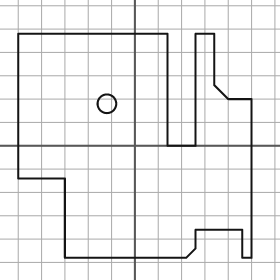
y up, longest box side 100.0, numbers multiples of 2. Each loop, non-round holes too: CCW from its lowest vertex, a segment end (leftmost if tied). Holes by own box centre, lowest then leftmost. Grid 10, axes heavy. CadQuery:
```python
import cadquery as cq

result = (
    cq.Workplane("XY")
    .moveTo(-30.0, -48.0)
    .lineTo(22.0, -48.0)
    .lineTo(26.0, -44.0)
    .lineTo(26.0, -36.0)
    .lineTo(46.0, -36.0)
    .lineTo(46.0, -48.0)
    .lineTo(50.0, -48.0)
    .lineTo(50.0, 20.0)
    .lineTo(40.0, 20.0)
    .lineTo(34.0, 26.0)
    .lineTo(34.0, 48.0)
    .lineTo(26.0, 48.0)
    .lineTo(26.0, 0.0)
    .lineTo(14.0, 0.0)
    .lineTo(14.0, 48.0)
    .lineTo(-50.0, 48.0)
    .lineTo(-50.0, -14.0)
    .lineTo(-30.0, -14.0)
    .close()
    .moveTo(-12.0, 18.0)
    .circle(4.0)
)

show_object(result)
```